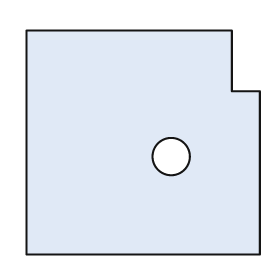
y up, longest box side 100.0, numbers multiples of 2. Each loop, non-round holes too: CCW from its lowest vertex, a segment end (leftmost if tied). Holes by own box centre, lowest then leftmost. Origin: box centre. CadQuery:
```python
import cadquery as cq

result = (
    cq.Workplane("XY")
    .moveTo(-50.0, -48.0)
    .lineTo(50.0, -48.0)
    .lineTo(50.0, 22.0)
    .lineTo(38.0, 22.0)
    .lineTo(38.0, 48.0)
    .lineTo(-50.0, 48.0)
    .close()
    .moveTo(12.0, -6.0)
    .circle(8.0)
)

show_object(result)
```